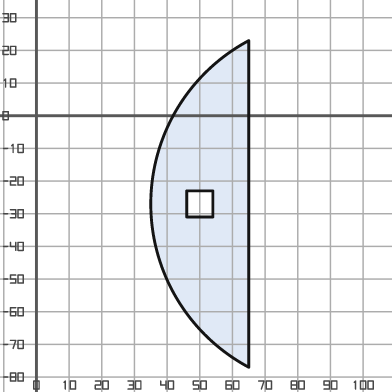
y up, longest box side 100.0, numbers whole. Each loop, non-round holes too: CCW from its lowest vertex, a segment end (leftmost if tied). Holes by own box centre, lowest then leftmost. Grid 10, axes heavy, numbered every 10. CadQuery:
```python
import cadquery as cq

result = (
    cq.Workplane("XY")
    .moveTo(65.0, -77.0)
    .lineTo(65.0, 23.0)
    .threePointArc((35.0, -27.0), (65.0, -77.0))
    .close()
    .moveTo(46.0, -31.0)
    .lineTo(54.0, -31.0)
    .lineTo(54.0, -23.0)
    .lineTo(46.0, -23.0)
    .close()
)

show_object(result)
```